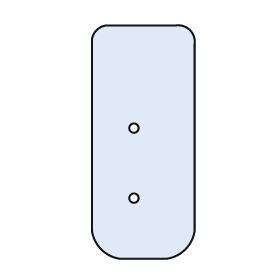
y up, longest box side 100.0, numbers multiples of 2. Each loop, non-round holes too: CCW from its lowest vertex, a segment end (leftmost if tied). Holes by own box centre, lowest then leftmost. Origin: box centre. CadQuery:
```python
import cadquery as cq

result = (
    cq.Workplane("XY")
    .moveTo(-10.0, -50.0)
    .lineTo(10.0, -50.0)
    .threePointArc((18.0, -46.0), (22.0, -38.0))
    .lineTo(22.0, 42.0)
    .threePointArc((20.0, 48.0), (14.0, 50.0))
    .lineTo(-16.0, 50.0)
    .threePointArc((-20.0, 48.0), (-22.0, 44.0))
    .lineTo(-22.0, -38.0)
    .threePointArc((-18.0, -46.0), (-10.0, -50.0))
    .close()
    .moveTo(-4.0, -24.0)
    .circle(2.0)
    .moveTo(-4.0, 6.0)
    .circle(2.0)
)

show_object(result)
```